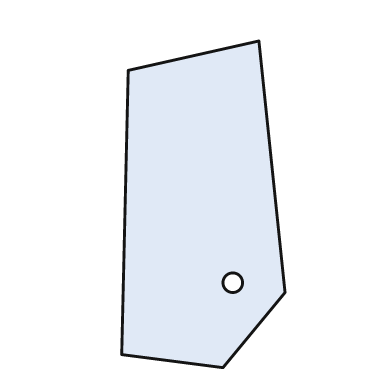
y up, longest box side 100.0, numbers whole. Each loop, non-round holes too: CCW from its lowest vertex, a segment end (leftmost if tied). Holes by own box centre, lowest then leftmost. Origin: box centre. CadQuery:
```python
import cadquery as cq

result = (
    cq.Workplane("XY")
    .moveTo(6.0, -50.0)
    .lineTo(25.0, -27.0)
    .lineTo(17.0, 50.0)
    .lineTo(-23.0, 41.0)
    .lineTo(-25.0, -46.0)
    .close()
    .moveTo(9.0, -24.0)
    .circle(3.0)
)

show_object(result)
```